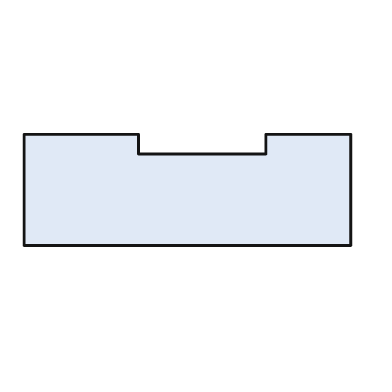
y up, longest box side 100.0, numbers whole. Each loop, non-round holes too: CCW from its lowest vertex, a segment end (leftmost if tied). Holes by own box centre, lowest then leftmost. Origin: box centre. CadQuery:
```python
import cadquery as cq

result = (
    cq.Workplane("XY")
    .moveTo(-50.0, -17.0)
    .lineTo(50.0, -17.0)
    .lineTo(50.0, 17.0)
    .lineTo(24.0, 17.0)
    .lineTo(24.0, 11.0)
    .lineTo(-15.0, 11.0)
    .lineTo(-15.0, 17.0)
    .lineTo(-50.0, 17.0)
    .close()
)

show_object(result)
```